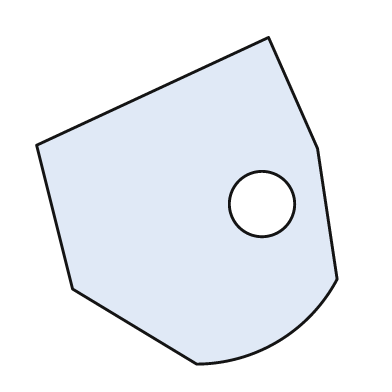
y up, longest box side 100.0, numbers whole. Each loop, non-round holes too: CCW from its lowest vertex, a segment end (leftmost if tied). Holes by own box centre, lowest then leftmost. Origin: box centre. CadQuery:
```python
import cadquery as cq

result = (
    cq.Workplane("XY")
    .moveTo(3.0, -50.0)
    .threePointArc((28.0, -43.0), (46.0, -24.0))
    .lineTo(40.0, 16.0)
    .lineTo(25.0, 50.0)
    .lineTo(-46.0, 17.0)
    .lineTo(-35.0, -27.0)
    .close()
    .moveTo(23.0, -1.0)
    .circle(10.0)
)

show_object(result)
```